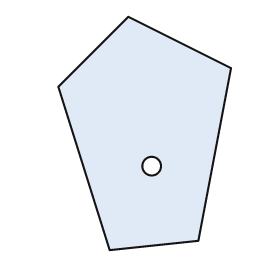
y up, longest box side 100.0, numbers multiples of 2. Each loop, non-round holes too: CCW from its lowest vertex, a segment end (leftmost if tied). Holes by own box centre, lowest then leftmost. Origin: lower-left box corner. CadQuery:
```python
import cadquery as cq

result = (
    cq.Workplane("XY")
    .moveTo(22.0, 0.0)
    .lineTo(60.0, 4.0)
    .lineTo(74.0, 78.0)
    .lineTo(30.0, 100.0)
    .lineTo(0.0, 70.0)
    .close()
    .moveTo(40.0, 36.0)
    .circle(4.0)
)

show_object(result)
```